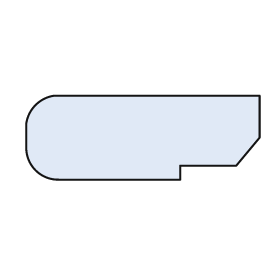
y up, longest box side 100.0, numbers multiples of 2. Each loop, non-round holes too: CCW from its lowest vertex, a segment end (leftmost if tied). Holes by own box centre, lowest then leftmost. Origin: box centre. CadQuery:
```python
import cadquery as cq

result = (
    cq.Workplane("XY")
    .moveTo(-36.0, -18.0)
    .lineTo(16.0, -18.0)
    .lineTo(16.0, -12.0)
    .lineTo(40.0, -12.0)
    .lineTo(50.0, 0.0)
    .lineTo(50.0, 18.0)
    .lineTo(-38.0, 18.0)
    .threePointArc((-46.0, 14.0), (-50.0, 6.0))
    .lineTo(-50.0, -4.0)
    .threePointArc((-46.0, -14.0), (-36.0, -18.0))
    .close()
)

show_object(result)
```